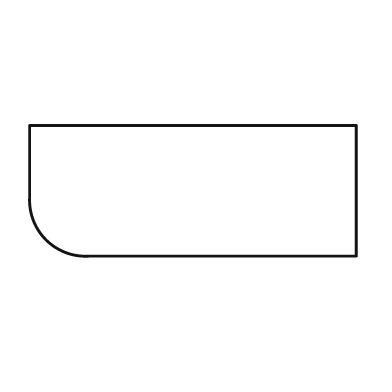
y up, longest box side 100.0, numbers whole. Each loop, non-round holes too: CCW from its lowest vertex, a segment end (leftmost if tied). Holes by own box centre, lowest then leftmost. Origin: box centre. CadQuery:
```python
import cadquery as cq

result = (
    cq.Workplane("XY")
    .moveTo(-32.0, -20.0)
    .lineTo(50.0, -20.0)
    .lineTo(50.0, 20.0)
    .lineTo(-50.0, 20.0)
    .lineTo(-50.0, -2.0)
    .threePointArc((-45.0, -15.0), (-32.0, -20.0))
    .close()
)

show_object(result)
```